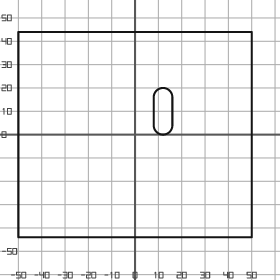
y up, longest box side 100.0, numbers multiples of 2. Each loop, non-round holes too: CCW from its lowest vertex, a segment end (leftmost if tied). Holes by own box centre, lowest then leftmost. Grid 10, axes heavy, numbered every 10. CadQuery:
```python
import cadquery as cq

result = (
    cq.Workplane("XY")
    .moveTo(-50.0, -44.0)
    .lineTo(50.0, -44.0)
    .lineTo(50.0, 44.0)
    .lineTo(-50.0, 44.0)
    .close()
    .moveTo(8.0, 4.0)
    .threePointArc((12.0, 0.0), (16.0, 4.0))
    .lineTo(16.0, 16.0)
    .threePointArc((12.0, 20.0), (8.0, 16.0))
    .close()
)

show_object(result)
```